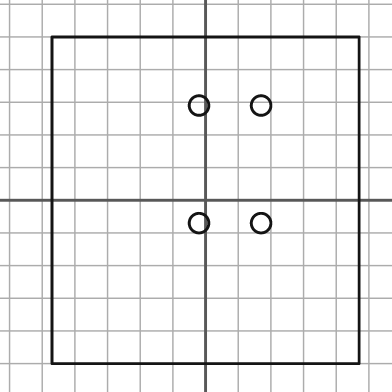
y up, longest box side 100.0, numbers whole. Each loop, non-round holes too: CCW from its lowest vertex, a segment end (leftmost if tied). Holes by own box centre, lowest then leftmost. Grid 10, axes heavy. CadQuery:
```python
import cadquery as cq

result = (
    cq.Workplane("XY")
    .moveTo(-47.0, -50.0)
    .lineTo(47.0, -50.0)
    .lineTo(47.0, 50.0)
    .lineTo(-47.0, 50.0)
    .close()
    .moveTo(-2.0, -7.0)
    .circle(3.0)
    .moveTo(17.0, -7.0)
    .circle(3.0)
    .moveTo(-2.0, 29.0)
    .circle(3.0)
    .moveTo(17.0, 29.0)
    .circle(3.0)
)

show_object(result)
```